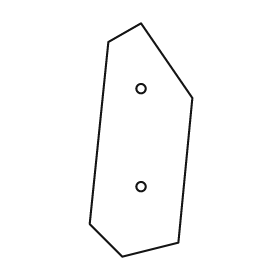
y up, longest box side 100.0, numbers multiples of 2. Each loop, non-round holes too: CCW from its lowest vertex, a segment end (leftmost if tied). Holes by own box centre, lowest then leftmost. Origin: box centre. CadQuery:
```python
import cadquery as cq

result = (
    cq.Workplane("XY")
    .moveTo(-8.0, -50.0)
    .lineTo(16.0, -44.0)
    .lineTo(22.0, 18.0)
    .lineTo(0.0, 50.0)
    .lineTo(-14.0, 42.0)
    .lineTo(-22.0, -36.0)
    .close()
    .moveTo(0.0, -20.0)
    .circle(2.0)
    .moveTo(0.0, 22.0)
    .circle(2.0)
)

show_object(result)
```